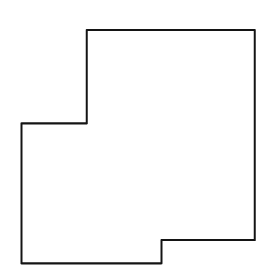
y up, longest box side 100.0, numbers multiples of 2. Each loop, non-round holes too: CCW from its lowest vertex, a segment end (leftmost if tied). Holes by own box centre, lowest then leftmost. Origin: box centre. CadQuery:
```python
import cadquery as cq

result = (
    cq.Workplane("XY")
    .moveTo(-50.0, -50.0)
    .lineTo(10.0, -50.0)
    .lineTo(10.0, -40.0)
    .lineTo(50.0, -40.0)
    .lineTo(50.0, 50.0)
    .lineTo(-22.0, 50.0)
    .lineTo(-22.0, 10.0)
    .lineTo(-50.0, 10.0)
    .close()
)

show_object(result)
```